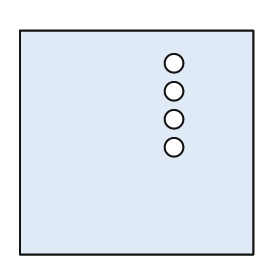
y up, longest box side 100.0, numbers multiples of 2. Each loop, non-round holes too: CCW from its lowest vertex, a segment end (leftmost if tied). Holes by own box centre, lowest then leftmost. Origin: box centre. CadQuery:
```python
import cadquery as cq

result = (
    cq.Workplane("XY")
    .moveTo(-50.0, -48.0)
    .lineTo(50.0, -48.0)
    .lineTo(50.0, 48.0)
    .lineTo(-50.0, 48.0)
    .close()
    .moveTo(16.0, -2.0)
    .circle(4.0)
    .moveTo(16.0, 10.0)
    .circle(4.0)
    .moveTo(16.0, 22.0)
    .circle(4.0)
    .moveTo(16.0, 34.0)
    .circle(4.0)
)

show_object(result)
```